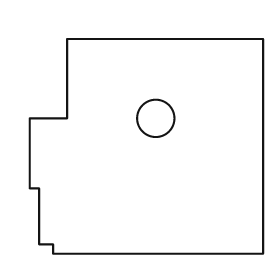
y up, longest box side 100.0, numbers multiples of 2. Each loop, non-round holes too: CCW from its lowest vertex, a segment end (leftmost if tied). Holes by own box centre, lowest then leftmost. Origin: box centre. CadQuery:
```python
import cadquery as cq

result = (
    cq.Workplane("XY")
    .moveTo(-40.0, -46.0)
    .lineTo(50.0, -46.0)
    .lineTo(50.0, 46.0)
    .lineTo(-34.0, 46.0)
    .lineTo(-34.0, 12.0)
    .lineTo(-50.0, 12.0)
    .lineTo(-50.0, -18.0)
    .lineTo(-46.0, -18.0)
    .lineTo(-46.0, -42.0)
    .lineTo(-40.0, -42.0)
    .close()
    .moveTo(4.0, 12.0)
    .circle(8.0)
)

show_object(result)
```